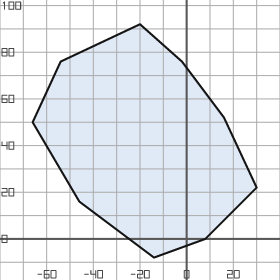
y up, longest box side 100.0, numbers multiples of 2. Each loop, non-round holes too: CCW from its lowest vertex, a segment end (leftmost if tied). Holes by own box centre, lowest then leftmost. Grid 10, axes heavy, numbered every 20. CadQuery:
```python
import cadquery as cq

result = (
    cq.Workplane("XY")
    .moveTo(-14.0, -8.0)
    .lineTo(8.0, 0.0)
    .lineTo(30.0, 22.0)
    .lineTo(16.0, 52.0)
    .lineTo(-2.0, 76.0)
    .lineTo(-20.0, 92.0)
    .lineTo(-54.0, 76.0)
    .lineTo(-66.0, 50.0)
    .lineTo(-46.0, 16.0)
    .close()
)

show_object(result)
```